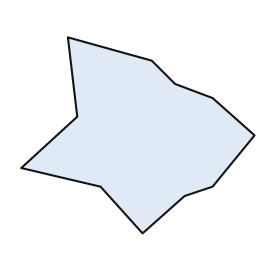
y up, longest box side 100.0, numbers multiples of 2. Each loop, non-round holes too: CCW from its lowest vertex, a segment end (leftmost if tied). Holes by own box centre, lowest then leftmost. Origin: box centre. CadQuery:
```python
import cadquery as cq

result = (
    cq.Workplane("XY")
    .moveTo(2.0, -42.0)
    .lineTo(20.0, -26.0)
    .lineTo(32.0, -22.0)
    .lineTo(50.0, 0.0)
    .lineTo(32.0, 16.0)
    .lineTo(16.0, 22.0)
    .lineTo(6.0, 32.0)
    .lineTo(-30.0, 42.0)
    .lineTo(-26.0, 8.0)
    .lineTo(-50.0, -14.0)
    .lineTo(-16.0, -22.0)
    .close()
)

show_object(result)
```